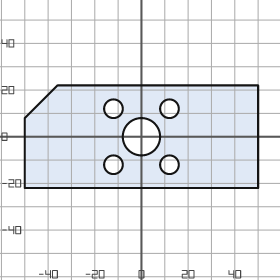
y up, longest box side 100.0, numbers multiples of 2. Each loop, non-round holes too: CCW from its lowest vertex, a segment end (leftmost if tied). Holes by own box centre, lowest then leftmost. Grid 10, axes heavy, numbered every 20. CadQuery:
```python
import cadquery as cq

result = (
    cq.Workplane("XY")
    .moveTo(-50.0, -22.0)
    .lineTo(50.0, -22.0)
    .lineTo(50.0, 22.0)
    .lineTo(-36.0, 22.0)
    .lineTo(-50.0, 8.0)
    .close()
    .moveTo(-12.0, -12.0)
    .circle(4.0)
    .moveTo(12.0, -12.0)
    .circle(4.0)
    .moveTo(0.0, 0.0)
    .circle(8.0)
    .moveTo(-12.0, 12.0)
    .circle(4.0)
    .moveTo(12.0, 12.0)
    .circle(4.0)
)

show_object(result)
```